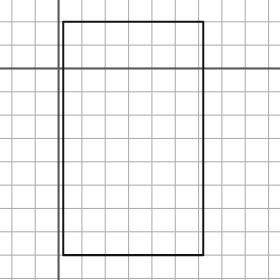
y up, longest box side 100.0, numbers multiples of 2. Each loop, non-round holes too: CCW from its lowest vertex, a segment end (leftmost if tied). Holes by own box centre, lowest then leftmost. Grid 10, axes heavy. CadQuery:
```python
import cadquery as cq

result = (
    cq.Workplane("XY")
    .moveTo(2.0, -80.0)
    .lineTo(62.0, -80.0)
    .lineTo(62.0, 20.0)
    .lineTo(2.0, 20.0)
    .close()
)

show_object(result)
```